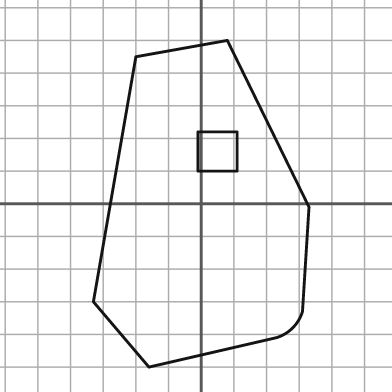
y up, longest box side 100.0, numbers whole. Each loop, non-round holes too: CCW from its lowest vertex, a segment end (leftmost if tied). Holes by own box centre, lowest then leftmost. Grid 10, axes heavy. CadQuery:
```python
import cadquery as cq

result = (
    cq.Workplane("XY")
    .moveTo(-16.0, -50.0)
    .lineTo(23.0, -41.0)
    .threePointArc((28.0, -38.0), (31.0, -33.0))
    .lineTo(33.0, -1.0)
    .lineTo(8.0, 50.0)
    .lineTo(-20.0, 45.0)
    .lineTo(-33.0, -30.0)
    .close()
    .moveTo(-1.0, 10.0)
    .lineTo(11.0, 10.0)
    .lineTo(11.0, 22.0)
    .lineTo(-1.0, 22.0)
    .close()
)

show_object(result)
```